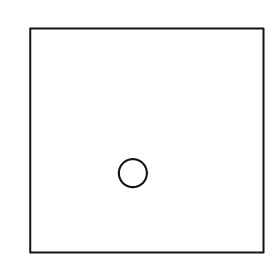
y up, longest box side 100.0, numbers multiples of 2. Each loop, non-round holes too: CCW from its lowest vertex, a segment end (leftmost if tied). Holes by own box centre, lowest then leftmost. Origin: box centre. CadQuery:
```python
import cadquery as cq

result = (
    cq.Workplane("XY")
    .moveTo(-50.0, -48.0)
    .lineTo(50.0, -48.0)
    .lineTo(50.0, 48.0)
    .lineTo(-50.0, 48.0)
    .close()
    .moveTo(-6.0, -14.0)
    .circle(6.0)
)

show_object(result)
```